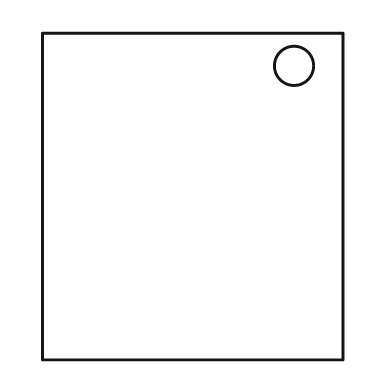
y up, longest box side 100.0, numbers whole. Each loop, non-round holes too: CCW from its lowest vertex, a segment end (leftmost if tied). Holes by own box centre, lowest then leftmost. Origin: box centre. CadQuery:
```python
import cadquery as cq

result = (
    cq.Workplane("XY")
    .moveTo(-46.0, -50.0)
    .lineTo(46.0, -50.0)
    .lineTo(46.0, 50.0)
    .lineTo(-46.0, 50.0)
    .close()
    .moveTo(31.0, 40.0)
    .circle(6.0)
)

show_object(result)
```